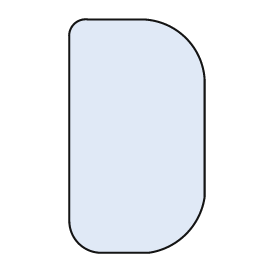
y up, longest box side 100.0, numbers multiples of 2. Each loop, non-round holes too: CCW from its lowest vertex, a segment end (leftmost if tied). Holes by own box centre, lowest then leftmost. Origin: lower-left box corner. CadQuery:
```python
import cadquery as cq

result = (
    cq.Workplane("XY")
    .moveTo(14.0, 0.0)
    .lineTo(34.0, 0.0)
    .threePointArc((50.0, 8.0), (58.0, 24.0))
    .lineTo(58.0, 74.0)
    .threePointArc((50.0, 92.0), (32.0, 100.0))
    .lineTo(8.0, 100.0)
    .threePointArc((2.0, 98.0), (0.0, 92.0))
    .lineTo(0.0, 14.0)
    .threePointArc((4.0, 4.0), (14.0, 0.0))
    .close()
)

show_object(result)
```